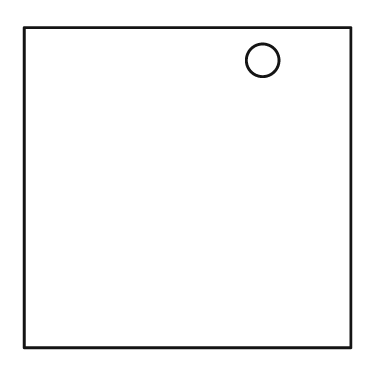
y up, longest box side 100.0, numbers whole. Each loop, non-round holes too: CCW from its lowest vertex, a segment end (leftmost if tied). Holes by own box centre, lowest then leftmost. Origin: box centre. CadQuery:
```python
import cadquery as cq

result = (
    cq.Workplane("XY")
    .moveTo(-50.0, -49.0)
    .lineTo(50.0, -49.0)
    .lineTo(50.0, 49.0)
    .lineTo(-50.0, 49.0)
    .close()
    .moveTo(23.0, 39.0)
    .circle(5.0)
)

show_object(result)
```